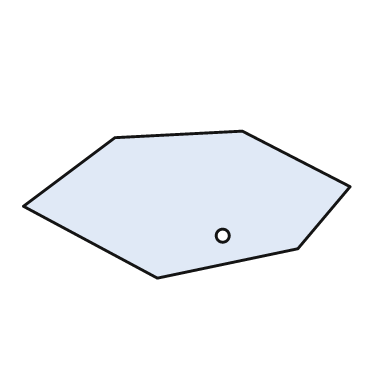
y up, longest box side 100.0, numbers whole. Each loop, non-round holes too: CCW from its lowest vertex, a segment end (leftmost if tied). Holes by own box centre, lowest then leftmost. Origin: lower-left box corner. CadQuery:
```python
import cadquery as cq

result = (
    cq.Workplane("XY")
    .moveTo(41.0, 0.0)
    .lineTo(84.0, 9.0)
    .lineTo(100.0, 28.0)
    .lineTo(67.0, 45.0)
    .lineTo(28.0, 43.0)
    .lineTo(0.0, 22.0)
    .close()
    .moveTo(61.0, 13.0)
    .circle(2.0)
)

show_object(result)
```